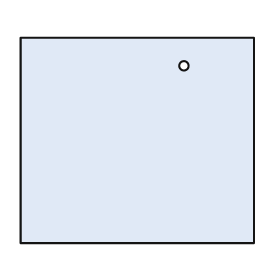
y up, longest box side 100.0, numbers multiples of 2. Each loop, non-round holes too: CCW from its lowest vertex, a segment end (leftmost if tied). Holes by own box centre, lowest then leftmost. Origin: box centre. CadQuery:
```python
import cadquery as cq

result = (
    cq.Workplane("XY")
    .moveTo(-50.0, -44.0)
    .lineTo(50.0, -44.0)
    .lineTo(50.0, 44.0)
    .lineTo(-50.0, 44.0)
    .close()
    .moveTo(20.0, 32.0)
    .circle(2.0)
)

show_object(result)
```